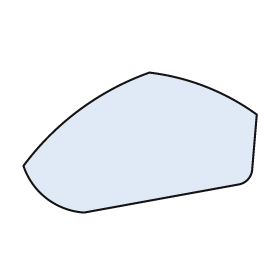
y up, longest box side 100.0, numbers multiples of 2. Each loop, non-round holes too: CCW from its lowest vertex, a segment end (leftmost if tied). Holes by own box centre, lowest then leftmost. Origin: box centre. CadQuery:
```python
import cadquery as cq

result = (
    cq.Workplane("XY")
    .moveTo(-24.0, -30.0)
    .lineTo(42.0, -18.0)
    .threePointArc((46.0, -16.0), (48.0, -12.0))
    .lineTo(50.0, 12.0)
    .threePointArc((28.0, 24.0), (4.0, 30.0))
    .threePointArc((-26.0, 14.0), (-50.0, -10.0))
    .threePointArc((-40.0, -24.0), (-24.0, -30.0))
    .close()
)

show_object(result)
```